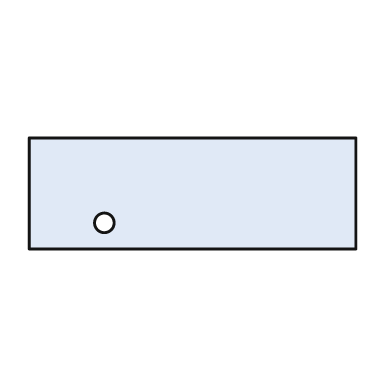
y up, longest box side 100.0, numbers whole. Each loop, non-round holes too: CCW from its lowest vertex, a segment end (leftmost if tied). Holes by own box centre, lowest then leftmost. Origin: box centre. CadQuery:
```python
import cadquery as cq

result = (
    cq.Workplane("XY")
    .moveTo(-50.0, -17.0)
    .lineTo(50.0, -17.0)
    .lineTo(50.0, 17.0)
    .lineTo(-50.0, 17.0)
    .close()
    .moveTo(-27.0, -9.0)
    .circle(3.0)
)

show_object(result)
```